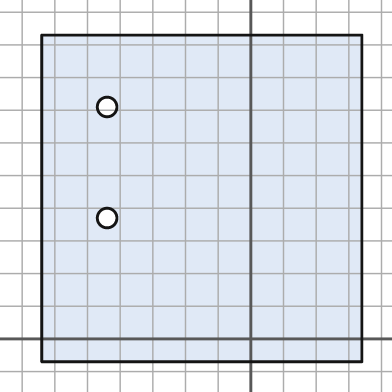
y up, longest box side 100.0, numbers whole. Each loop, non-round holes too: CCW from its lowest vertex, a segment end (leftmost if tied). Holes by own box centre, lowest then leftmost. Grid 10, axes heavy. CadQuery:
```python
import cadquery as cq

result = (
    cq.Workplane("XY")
    .moveTo(-64.0, -7.0)
    .lineTo(34.0, -7.0)
    .lineTo(34.0, 93.0)
    .lineTo(-64.0, 93.0)
    .close()
    .moveTo(-44.0, 37.0)
    .circle(3.0)
    .moveTo(-44.0, 71.0)
    .circle(3.0)
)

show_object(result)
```